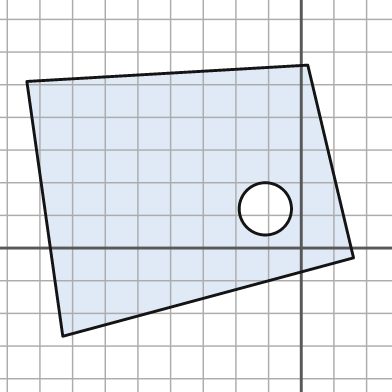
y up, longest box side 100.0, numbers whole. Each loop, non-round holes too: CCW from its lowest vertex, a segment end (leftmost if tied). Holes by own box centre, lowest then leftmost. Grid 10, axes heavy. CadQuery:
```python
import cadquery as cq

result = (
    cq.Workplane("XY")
    .moveTo(-73.0, -27.0)
    .lineTo(16.0, -3.0)
    .lineTo(2.0, 56.0)
    .lineTo(-84.0, 51.0)
    .close()
    .moveTo(-11.0, 12.0)
    .circle(8.0)
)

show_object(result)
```